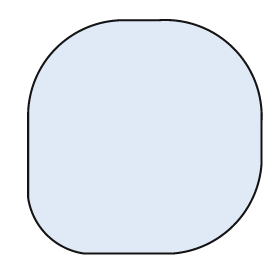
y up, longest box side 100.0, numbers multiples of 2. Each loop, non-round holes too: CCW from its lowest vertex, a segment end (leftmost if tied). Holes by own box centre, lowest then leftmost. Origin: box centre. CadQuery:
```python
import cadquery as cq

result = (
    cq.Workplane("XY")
    .moveTo(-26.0, -50.0)
    .lineTo(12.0, -50.0)
    .threePointArc((38.0, -38.0), (50.0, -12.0))
    .lineTo(50.0, 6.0)
    .threePointArc((38.0, 38.0), (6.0, 50.0))
    .lineTo(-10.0, 50.0)
    .threePointArc((-38.0, 38.0), (-50.0, 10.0))
    .lineTo(-50.0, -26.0)
    .threePointArc((-42.0, -42.0), (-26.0, -50.0))
    .close()
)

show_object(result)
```